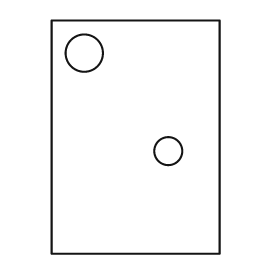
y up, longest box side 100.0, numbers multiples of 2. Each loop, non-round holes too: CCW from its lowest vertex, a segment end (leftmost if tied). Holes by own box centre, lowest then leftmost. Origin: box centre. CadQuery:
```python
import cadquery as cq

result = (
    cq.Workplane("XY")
    .moveTo(-36.0, -50.0)
    .lineTo(36.0, -50.0)
    .lineTo(36.0, 50.0)
    .lineTo(-36.0, 50.0)
    .close()
    .moveTo(14.0, -6.0)
    .circle(6.0)
    .moveTo(-22.0, 36.0)
    .circle(8.0)
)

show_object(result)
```